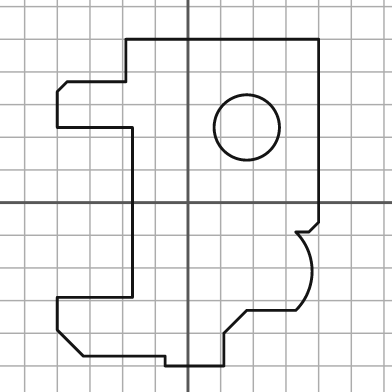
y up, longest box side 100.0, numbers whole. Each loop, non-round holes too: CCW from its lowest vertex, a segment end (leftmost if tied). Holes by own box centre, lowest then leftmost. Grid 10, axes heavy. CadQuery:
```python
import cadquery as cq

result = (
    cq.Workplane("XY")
    .moveTo(-7.0, -50.0)
    .lineTo(11.0, -50.0)
    .lineTo(11.0, -40.0)
    .lineTo(18.0, -33.0)
    .lineTo(33.0, -33.0)
    .threePointArc((38.0, -21.0), (33.0, -9.0))
    .lineTo(37.0, -9.0)
    .lineTo(40.0, -6.0)
    .lineTo(40.0, 50.0)
    .lineTo(-19.0, 50.0)
    .lineTo(-19.0, 37.0)
    .lineTo(-37.0, 37.0)
    .lineTo(-40.0, 34.0)
    .lineTo(-40.0, 23.0)
    .lineTo(-17.0, 23.0)
    .lineTo(-17.0, -29.0)
    .lineTo(-40.0, -29.0)
    .lineTo(-40.0, -39.0)
    .lineTo(-32.0, -47.0)
    .lineTo(-7.0, -47.0)
    .close()
    .moveTo(18.0, 23.0)
    .circle(10.0)
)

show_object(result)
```